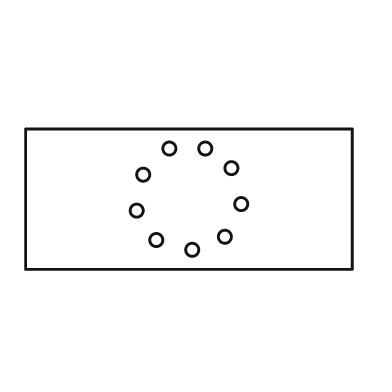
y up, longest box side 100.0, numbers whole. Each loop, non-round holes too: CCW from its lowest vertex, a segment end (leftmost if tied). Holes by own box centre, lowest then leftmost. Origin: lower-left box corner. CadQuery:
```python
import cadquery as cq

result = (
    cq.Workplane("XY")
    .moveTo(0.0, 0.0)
    .lineTo(100.0, 0.0)
    .lineTo(100.0, 43.0)
    .lineTo(0.0, 43.0)
    .close()
    .moveTo(51.0, 6.0)
    .circle(2.0)
    .moveTo(40.0, 9.0)
    .circle(2.0)
    .moveTo(61.0, 10.0)
    .circle(2.0)
    .moveTo(34.0, 18.0)
    .circle(2.0)
    .moveTo(66.0, 20.0)
    .circle(2.0)
    .moveTo(36.0, 29.0)
    .circle(2.0)
    .moveTo(63.0, 31.0)
    .circle(2.0)
    .moveTo(44.0, 37.0)
    .circle(2.0)
    .moveTo(55.0, 37.0)
    .circle(2.0)
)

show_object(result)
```